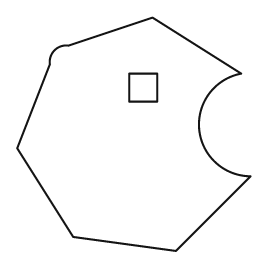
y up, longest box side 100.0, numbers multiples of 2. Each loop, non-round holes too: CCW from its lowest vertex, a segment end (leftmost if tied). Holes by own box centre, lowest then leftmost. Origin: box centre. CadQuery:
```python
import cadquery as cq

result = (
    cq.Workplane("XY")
    .moveTo(18.0, -50.0)
    .lineTo(50.0, -18.0)
    .threePointArc((28.0, 2.0), (46.0, 26.0))
    .lineTo(8.0, 50.0)
    .lineTo(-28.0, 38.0)
    .threePointArc((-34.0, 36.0), (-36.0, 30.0))
    .lineTo(-50.0, -6.0)
    .lineTo(-26.0, -44.0)
    .close()
    .moveTo(-2.0, 14.0)
    .lineTo(10.0, 14.0)
    .lineTo(10.0, 26.0)
    .lineTo(-2.0, 26.0)
    .close()
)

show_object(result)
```